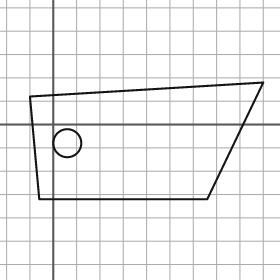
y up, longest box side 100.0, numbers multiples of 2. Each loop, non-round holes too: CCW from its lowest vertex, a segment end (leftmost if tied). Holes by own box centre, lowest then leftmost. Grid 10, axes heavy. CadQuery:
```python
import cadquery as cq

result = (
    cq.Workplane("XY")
    .moveTo(-6.0, -32.0)
    .lineTo(66.0, -32.0)
    .lineTo(90.0, 18.0)
    .lineTo(-10.0, 12.0)
    .close()
    .moveTo(6.0, -8.0)
    .circle(6.0)
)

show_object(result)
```